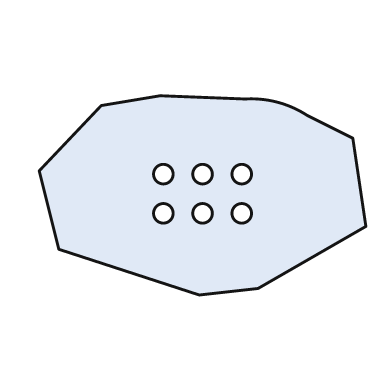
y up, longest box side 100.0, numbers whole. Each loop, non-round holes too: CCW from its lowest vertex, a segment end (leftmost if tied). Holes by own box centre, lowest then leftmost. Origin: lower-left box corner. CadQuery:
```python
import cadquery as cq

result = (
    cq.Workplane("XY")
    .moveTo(49.0, 0.0)
    .lineTo(67.0, 2.0)
    .lineTo(100.0, 21.0)
    .lineTo(96.0, 48.0)
    .lineTo(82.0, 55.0)
    .threePointArc((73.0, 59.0), (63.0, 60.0))
    .lineTo(37.0, 61.0)
    .lineTo(19.0, 58.0)
    .lineTo(0.0, 38.0)
    .lineTo(6.0, 14.0)
    .close()
    .moveTo(38.0, 25.0)
    .circle(3.0)
    .moveTo(50.0, 25.0)
    .circle(3.0)
    .moveTo(62.0, 25.0)
    .circle(3.0)
    .moveTo(38.0, 37.0)
    .circle(3.0)
    .moveTo(50.0, 37.0)
    .circle(3.0)
    .moveTo(62.0, 37.0)
    .circle(3.0)
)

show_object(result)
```